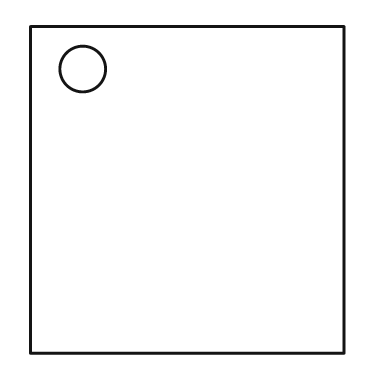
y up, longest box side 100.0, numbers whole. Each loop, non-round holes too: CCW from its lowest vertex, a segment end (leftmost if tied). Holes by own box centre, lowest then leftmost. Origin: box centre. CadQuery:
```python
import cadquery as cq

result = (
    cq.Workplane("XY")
    .moveTo(-48.0, -50.0)
    .lineTo(48.0, -50.0)
    .lineTo(48.0, 50.0)
    .lineTo(-48.0, 50.0)
    .close()
    .moveTo(-32.0, 37.0)
    .circle(7.0)
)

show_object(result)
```